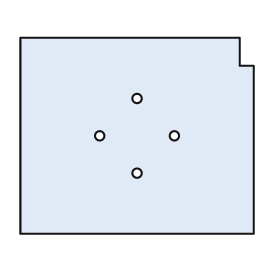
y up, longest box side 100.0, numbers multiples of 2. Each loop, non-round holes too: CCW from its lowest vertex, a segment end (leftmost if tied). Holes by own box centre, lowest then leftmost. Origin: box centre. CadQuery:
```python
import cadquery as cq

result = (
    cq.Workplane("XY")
    .moveTo(-50.0, -42.0)
    .lineTo(50.0, -42.0)
    .lineTo(50.0, 30.0)
    .lineTo(44.0, 30.0)
    .lineTo(44.0, 42.0)
    .lineTo(-50.0, 42.0)
    .close()
    .moveTo(0.0, -16.0)
    .circle(2.0)
    .moveTo(-16.0, 0.0)
    .circle(2.0)
    .moveTo(16.0, 0.0)
    .circle(2.0)
    .moveTo(0.0, 16.0)
    .circle(2.0)
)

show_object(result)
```